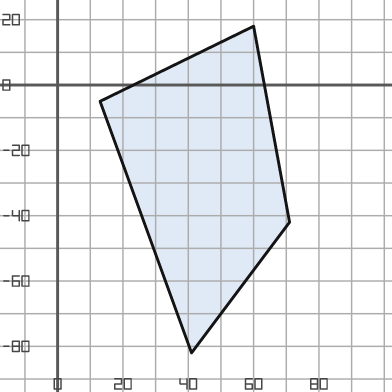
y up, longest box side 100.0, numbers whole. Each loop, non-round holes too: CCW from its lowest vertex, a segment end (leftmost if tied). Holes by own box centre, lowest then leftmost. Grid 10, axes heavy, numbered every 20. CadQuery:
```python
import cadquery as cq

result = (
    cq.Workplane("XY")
    .moveTo(41.0, -82.0)
    .lineTo(71.0, -42.0)
    .lineTo(60.0, 18.0)
    .lineTo(13.0, -5.0)
    .close()
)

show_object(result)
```